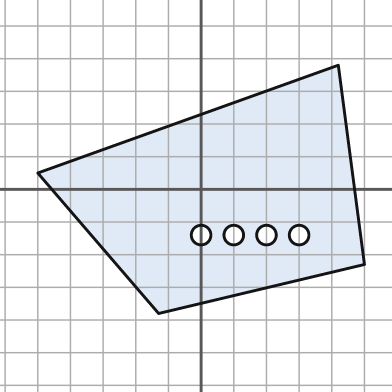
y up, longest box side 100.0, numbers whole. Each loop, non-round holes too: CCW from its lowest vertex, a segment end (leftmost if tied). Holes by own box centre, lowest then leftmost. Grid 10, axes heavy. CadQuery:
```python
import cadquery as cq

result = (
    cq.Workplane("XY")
    .moveTo(-13.0, -38.0)
    .lineTo(50.0, -23.0)
    .lineTo(42.0, 38.0)
    .lineTo(-50.0, 5.0)
    .close()
    .moveTo(0.0, -14.0)
    .circle(3.0)
    .moveTo(10.0, -14.0)
    .circle(3.0)
    .moveTo(20.0, -14.0)
    .circle(3.0)
    .moveTo(30.0, -14.0)
    .circle(3.0)
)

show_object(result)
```